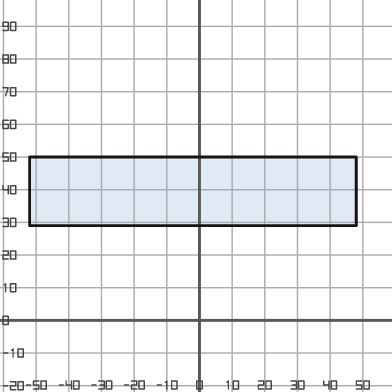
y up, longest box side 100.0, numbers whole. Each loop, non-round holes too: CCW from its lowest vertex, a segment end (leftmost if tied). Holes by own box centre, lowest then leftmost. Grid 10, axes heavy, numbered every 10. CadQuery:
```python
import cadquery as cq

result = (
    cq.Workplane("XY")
    .moveTo(-52.0, 29.0)
    .lineTo(48.0, 29.0)
    .lineTo(48.0, 50.0)
    .lineTo(-52.0, 50.0)
    .close()
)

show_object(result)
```